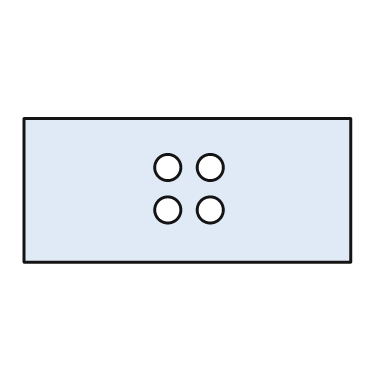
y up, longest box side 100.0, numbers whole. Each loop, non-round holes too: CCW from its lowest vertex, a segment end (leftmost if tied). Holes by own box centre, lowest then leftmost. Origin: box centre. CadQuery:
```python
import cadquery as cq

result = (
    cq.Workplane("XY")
    .moveTo(-50.0, -22.0)
    .lineTo(50.0, -22.0)
    .lineTo(50.0, 22.0)
    .lineTo(-50.0, 22.0)
    .close()
    .moveTo(-6.0, -6.0)
    .circle(4.0)
    .moveTo(7.0, -6.0)
    .circle(4.0)
    .moveTo(-6.0, 7.0)
    .circle(4.0)
    .moveTo(7.0, 7.0)
    .circle(4.0)
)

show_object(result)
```